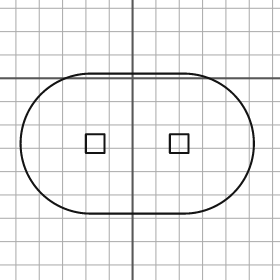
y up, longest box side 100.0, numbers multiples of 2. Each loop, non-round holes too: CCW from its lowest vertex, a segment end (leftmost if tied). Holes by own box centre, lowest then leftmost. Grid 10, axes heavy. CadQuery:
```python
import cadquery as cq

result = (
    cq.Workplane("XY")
    .moveTo(-18.0, -58.0)
    .lineTo(22.0, -58.0)
    .threePointArc((52.0, -28.0), (22.0, 2.0))
    .lineTo(-18.0, 2.0)
    .threePointArc((-48.0, -28.0), (-18.0, -58.0))
    .close()
    .moveTo(-20.0, -32.0)
    .lineTo(-12.0, -32.0)
    .lineTo(-12.0, -24.0)
    .lineTo(-20.0, -24.0)
    .close()
    .moveTo(16.0, -32.0)
    .lineTo(24.0, -32.0)
    .lineTo(24.0, -24.0)
    .lineTo(16.0, -24.0)
    .close()
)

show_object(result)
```